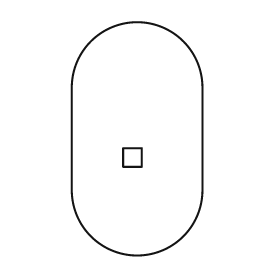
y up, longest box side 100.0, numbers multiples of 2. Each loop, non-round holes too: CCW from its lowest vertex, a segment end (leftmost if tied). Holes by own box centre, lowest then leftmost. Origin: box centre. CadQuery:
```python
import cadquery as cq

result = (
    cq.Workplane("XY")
    .moveTo(-28.0, -22.0)
    .threePointArc((0.0, -50.0), (28.0, -22.0))
    .lineTo(28.0, 22.0)
    .threePointArc((0.0, 50.0), (-28.0, 22.0))
    .close()
    .moveTo(-6.0, -12.0)
    .lineTo(2.0, -12.0)
    .lineTo(2.0, -4.0)
    .lineTo(-6.0, -4.0)
    .close()
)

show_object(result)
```